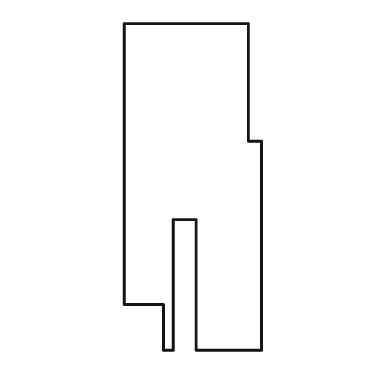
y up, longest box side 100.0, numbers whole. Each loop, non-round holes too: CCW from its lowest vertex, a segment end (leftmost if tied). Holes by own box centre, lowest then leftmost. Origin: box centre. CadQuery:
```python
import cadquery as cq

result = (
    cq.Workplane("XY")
    .moveTo(-9.0, -50.0)
    .lineTo(-6.0, -50.0)
    .lineTo(-6.0, -10.0)
    .lineTo(1.0, -10.0)
    .lineTo(1.0, -50.0)
    .lineTo(21.0, -50.0)
    .lineTo(21.0, 14.0)
    .lineTo(17.0, 14.0)
    .lineTo(17.0, 50.0)
    .lineTo(-21.0, 50.0)
    .lineTo(-21.0, -36.0)
    .lineTo(-9.0, -36.0)
    .close()
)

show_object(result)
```